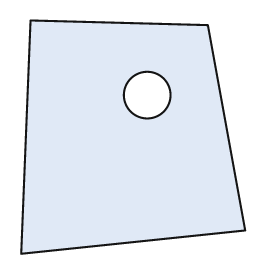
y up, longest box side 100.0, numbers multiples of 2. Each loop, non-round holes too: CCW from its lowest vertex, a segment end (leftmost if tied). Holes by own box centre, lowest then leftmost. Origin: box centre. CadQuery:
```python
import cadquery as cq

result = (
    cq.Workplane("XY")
    .moveTo(-48.0, -50.0)
    .lineTo(48.0, -40.0)
    .lineTo(32.0, 48.0)
    .lineTo(-44.0, 50.0)
    .close()
    .moveTo(6.0, 18.0)
    .circle(10.0)
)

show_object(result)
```